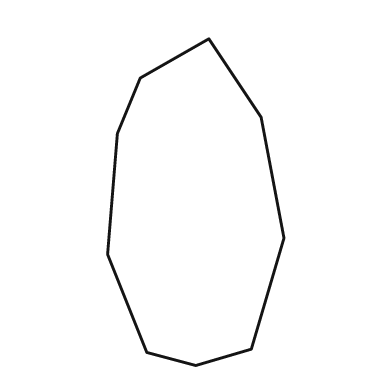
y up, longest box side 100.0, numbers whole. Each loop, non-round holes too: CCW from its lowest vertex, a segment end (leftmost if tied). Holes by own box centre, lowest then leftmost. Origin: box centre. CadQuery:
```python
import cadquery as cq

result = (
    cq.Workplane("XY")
    .moveTo(0.0, -50.0)
    .lineTo(17.0, -45.0)
    .lineTo(27.0, -11.0)
    .lineTo(20.0, 26.0)
    .lineTo(4.0, 50.0)
    .lineTo(-17.0, 38.0)
    .lineTo(-24.0, 21.0)
    .lineTo(-27.0, -16.0)
    .lineTo(-15.0, -46.0)
    .close()
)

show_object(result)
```